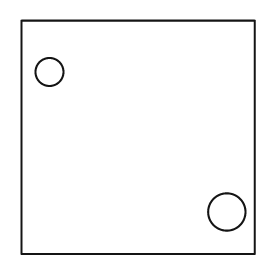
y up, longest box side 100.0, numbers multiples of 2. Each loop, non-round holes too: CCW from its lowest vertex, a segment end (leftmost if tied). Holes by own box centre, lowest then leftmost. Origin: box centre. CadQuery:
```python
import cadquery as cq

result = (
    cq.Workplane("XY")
    .moveTo(-50.0, -50.0)
    .lineTo(50.0, -50.0)
    .lineTo(50.0, 50.0)
    .lineTo(-50.0, 50.0)
    .close()
    .moveTo(38.0, -32.0)
    .circle(8.0)
    .moveTo(-38.0, 28.0)
    .circle(6.0)
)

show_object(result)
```